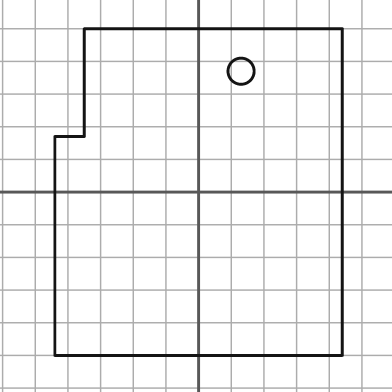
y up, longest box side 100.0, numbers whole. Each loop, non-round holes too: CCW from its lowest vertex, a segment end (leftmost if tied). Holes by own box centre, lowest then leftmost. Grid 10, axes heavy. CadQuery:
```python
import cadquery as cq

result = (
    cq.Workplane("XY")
    .moveTo(-44.0, -50.0)
    .lineTo(44.0, -50.0)
    .lineTo(44.0, 50.0)
    .lineTo(-35.0, 50.0)
    .lineTo(-35.0, 17.0)
    .lineTo(-44.0, 17.0)
    .close()
    .moveTo(13.0, 37.0)
    .circle(4.0)
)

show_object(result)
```